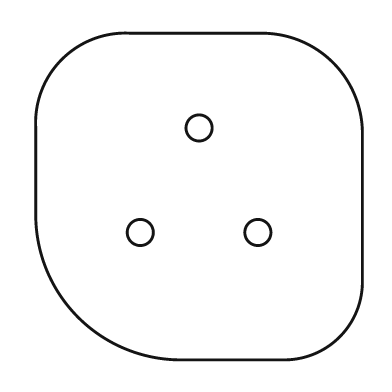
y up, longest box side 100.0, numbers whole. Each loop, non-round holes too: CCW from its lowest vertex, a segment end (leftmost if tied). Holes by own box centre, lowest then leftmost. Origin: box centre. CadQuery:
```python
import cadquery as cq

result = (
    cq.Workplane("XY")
    .moveTo(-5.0, -50.0)
    .lineTo(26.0, -50.0)
    .threePointArc((43.0, -43.0), (50.0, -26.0))
    .lineTo(50.0, 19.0)
    .threePointArc((41.0, 41.0), (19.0, 50.0))
    .lineTo(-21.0, 50.0)
    .threePointArc((-42.0, 42.0), (-50.0, 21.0))
    .lineTo(-50.0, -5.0)
    .threePointArc((-37.0, -37.0), (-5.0, -50.0))
    .close()
    .moveTo(-18.0, -11.0)
    .circle(4.0)
    .moveTo(18.0, -11.0)
    .circle(4.0)
    .moveTo(0.0, 21.0)
    .circle(4.0)
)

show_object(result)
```